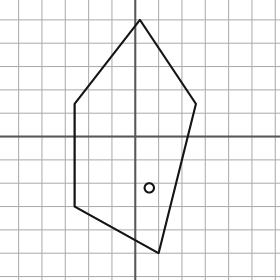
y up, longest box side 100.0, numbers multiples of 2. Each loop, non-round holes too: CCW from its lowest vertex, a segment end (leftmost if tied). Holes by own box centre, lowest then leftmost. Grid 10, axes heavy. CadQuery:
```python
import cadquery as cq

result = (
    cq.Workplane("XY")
    .moveTo(10.0, -50.0)
    .lineTo(26.0, 14.0)
    .lineTo(2.0, 50.0)
    .lineTo(-26.0, 14.0)
    .lineTo(-26.0, -30.0)
    .close()
    .moveTo(6.0, -22.0)
    .circle(2.0)
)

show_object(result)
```